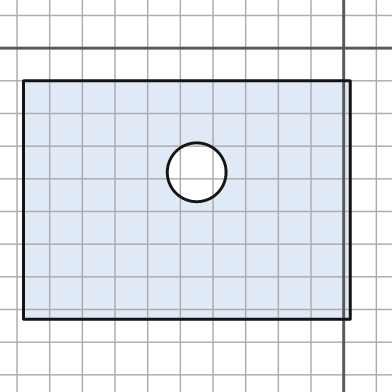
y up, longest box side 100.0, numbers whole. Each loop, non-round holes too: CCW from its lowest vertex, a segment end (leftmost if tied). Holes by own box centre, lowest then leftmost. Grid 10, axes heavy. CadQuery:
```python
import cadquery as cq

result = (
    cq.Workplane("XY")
    .moveTo(-98.0, -83.0)
    .lineTo(2.0, -83.0)
    .lineTo(2.0, -10.0)
    .lineTo(-98.0, -10.0)
    .close()
    .moveTo(-45.0, -38.0)
    .circle(9.0)
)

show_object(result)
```